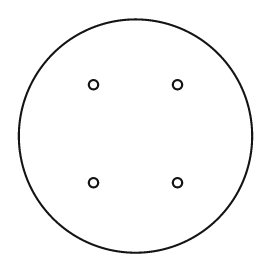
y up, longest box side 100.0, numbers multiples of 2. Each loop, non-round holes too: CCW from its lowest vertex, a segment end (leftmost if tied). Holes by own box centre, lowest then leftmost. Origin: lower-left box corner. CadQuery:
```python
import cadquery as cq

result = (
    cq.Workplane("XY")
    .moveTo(50.0, 50.0)
    .circle(50.0)
    .moveTo(32.0, 30.0)
    .circle(2.0)
    .moveTo(68.0, 30.0)
    .circle(2.0)
    .moveTo(32.0, 72.0)
    .circle(2.0)
    .moveTo(68.0, 72.0)
    .circle(2.0)
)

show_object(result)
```